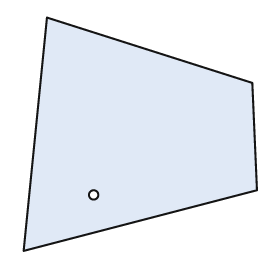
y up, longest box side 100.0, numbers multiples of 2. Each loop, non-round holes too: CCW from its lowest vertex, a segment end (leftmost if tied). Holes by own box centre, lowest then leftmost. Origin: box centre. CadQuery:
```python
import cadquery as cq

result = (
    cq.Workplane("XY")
    .moveTo(-50.0, -50.0)
    .lineTo(50.0, -24.0)
    .lineTo(48.0, 22.0)
    .lineTo(-40.0, 50.0)
    .close()
    .moveTo(-20.0, -26.0)
    .circle(2.0)
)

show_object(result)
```